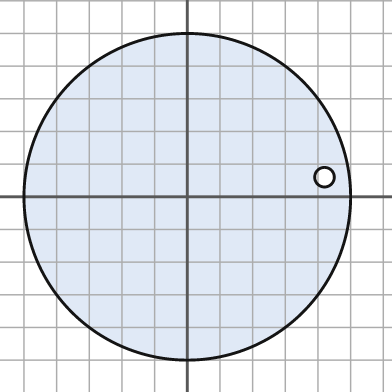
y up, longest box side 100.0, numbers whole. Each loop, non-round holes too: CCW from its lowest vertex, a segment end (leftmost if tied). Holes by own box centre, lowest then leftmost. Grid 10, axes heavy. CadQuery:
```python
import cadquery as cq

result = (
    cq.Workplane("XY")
    .moveTo(0.0, 0.0)
    .circle(50.0)
    .moveTo(42.0, 6.0)
    .circle(3.0)
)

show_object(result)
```